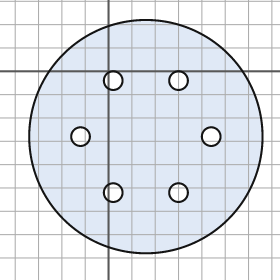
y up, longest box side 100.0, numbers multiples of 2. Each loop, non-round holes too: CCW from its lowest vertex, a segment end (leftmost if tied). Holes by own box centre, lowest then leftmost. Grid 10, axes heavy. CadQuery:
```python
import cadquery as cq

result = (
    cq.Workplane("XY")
    .moveTo(16.0, -28.0)
    .circle(50.0)
    .moveTo(2.0, -52.0)
    .circle(4.0)
    .moveTo(30.0, -52.0)
    .circle(4.0)
    .moveTo(-12.0, -28.0)
    .circle(4.0)
    .moveTo(44.0, -28.0)
    .circle(4.0)
    .moveTo(2.0, -4.0)
    .circle(4.0)
    .moveTo(30.0, -4.0)
    .circle(4.0)
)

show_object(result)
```